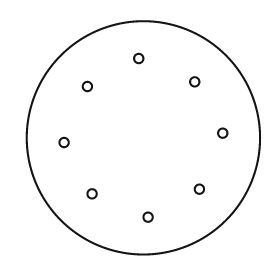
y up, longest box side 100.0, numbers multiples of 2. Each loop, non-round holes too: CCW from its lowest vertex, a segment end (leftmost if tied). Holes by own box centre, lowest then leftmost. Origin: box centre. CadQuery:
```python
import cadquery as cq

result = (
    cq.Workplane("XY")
    .moveTo(0.0, 0.0)
    .circle(50.0)
    .moveTo(2.0, -34.0)
    .circle(2.0)
    .moveTo(-22.0, -24.0)
    .circle(2.0)
    .moveTo(24.0, -22.0)
    .circle(2.0)
    .moveTo(-34.0, -2.0)
    .circle(2.0)
    .moveTo(34.0, 2.0)
    .circle(2.0)
    .moveTo(-24.0, 22.0)
    .circle(2.0)
    .moveTo(22.0, 24.0)
    .circle(2.0)
    .moveTo(-2.0, 34.0)
    .circle(2.0)
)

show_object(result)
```